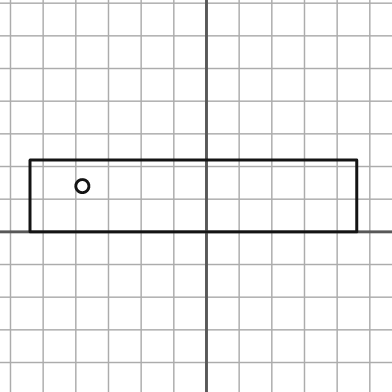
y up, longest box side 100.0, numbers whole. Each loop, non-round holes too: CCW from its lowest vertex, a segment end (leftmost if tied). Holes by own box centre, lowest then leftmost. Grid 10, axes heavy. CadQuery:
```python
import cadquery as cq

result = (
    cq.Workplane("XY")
    .moveTo(-54.0, 0.0)
    .lineTo(46.0, 0.0)
    .lineTo(46.0, 22.0)
    .lineTo(-54.0, 22.0)
    .close()
    .moveTo(-38.0, 14.0)
    .circle(2.0)
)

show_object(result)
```